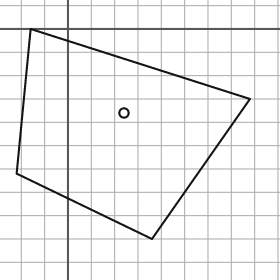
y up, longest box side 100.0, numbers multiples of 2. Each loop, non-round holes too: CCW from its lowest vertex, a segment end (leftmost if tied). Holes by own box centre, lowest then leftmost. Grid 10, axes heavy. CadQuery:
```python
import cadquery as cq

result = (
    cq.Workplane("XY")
    .moveTo(36.0, -90.0)
    .lineTo(78.0, -30.0)
    .lineTo(-16.0, 0.0)
    .lineTo(-22.0, -62.0)
    .close()
    .moveTo(24.0, -36.0)
    .circle(2.0)
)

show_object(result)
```